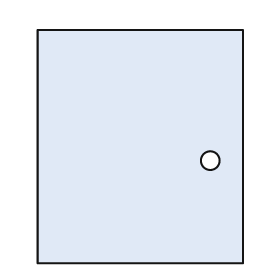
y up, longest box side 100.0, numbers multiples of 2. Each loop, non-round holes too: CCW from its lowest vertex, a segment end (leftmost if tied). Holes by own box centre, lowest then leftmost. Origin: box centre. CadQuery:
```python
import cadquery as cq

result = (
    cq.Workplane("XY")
    .moveTo(-44.0, -50.0)
    .lineTo(44.0, -50.0)
    .lineTo(44.0, 50.0)
    .lineTo(-44.0, 50.0)
    .close()
    .moveTo(30.0, -6.0)
    .circle(4.0)
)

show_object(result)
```